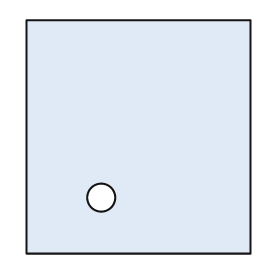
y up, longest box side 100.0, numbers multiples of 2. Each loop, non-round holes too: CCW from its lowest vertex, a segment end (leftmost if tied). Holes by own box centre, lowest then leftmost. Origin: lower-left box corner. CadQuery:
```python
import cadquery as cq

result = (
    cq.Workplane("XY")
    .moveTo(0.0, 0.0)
    .lineTo(96.0, 0.0)
    .lineTo(96.0, 100.0)
    .lineTo(0.0, 100.0)
    .close()
    .moveTo(32.0, 24.0)
    .circle(6.0)
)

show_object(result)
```